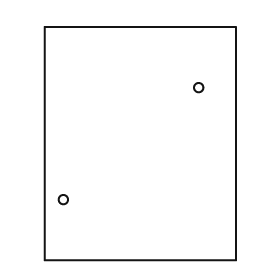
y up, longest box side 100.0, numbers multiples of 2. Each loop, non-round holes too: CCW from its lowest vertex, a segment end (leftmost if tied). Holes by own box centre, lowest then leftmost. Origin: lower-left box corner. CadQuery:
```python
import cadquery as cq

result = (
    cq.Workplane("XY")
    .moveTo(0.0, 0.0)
    .lineTo(82.0, 0.0)
    .lineTo(82.0, 100.0)
    .lineTo(0.0, 100.0)
    .close()
    .moveTo(8.0, 26.0)
    .circle(2.0)
    .moveTo(66.0, 74.0)
    .circle(2.0)
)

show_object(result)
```